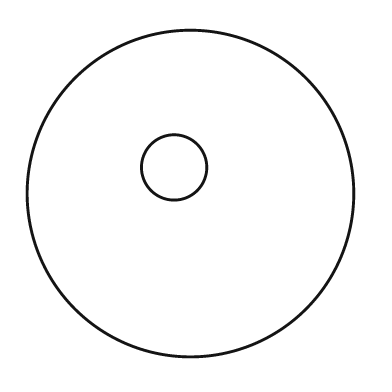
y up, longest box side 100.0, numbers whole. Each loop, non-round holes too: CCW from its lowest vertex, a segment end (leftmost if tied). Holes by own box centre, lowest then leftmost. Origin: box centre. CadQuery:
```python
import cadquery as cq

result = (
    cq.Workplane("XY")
    .moveTo(0.0, 0.0)
    .circle(50.0)
    .moveTo(-5.0, 8.0)
    .circle(10.0)
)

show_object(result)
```